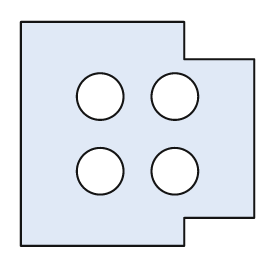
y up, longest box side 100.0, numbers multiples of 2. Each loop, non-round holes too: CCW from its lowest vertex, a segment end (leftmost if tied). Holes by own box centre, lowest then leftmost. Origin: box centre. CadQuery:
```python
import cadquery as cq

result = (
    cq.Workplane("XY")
    .moveTo(-50.0, -48.0)
    .lineTo(20.0, -48.0)
    .lineTo(20.0, -36.0)
    .lineTo(50.0, -36.0)
    .lineTo(50.0, 32.0)
    .lineTo(20.0, 32.0)
    .lineTo(20.0, 48.0)
    .lineTo(-50.0, 48.0)
    .close()
    .moveTo(-16.0, -16.0)
    .circle(10.0)
    .moveTo(16.0, -16.0)
    .circle(10.0)
    .moveTo(-16.0, 16.0)
    .circle(10.0)
    .moveTo(16.0, 16.0)
    .circle(10.0)
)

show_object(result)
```